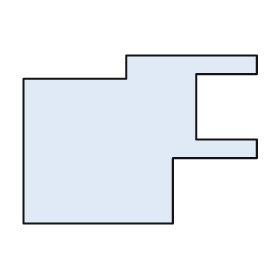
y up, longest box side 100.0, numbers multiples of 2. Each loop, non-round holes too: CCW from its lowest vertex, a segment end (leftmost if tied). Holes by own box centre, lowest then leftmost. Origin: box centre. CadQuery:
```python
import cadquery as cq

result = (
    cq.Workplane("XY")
    .moveTo(-50.0, -36.0)
    .lineTo(14.0, -36.0)
    .lineTo(14.0, -8.0)
    .lineTo(50.0, -8.0)
    .lineTo(50.0, 0.0)
    .lineTo(24.0, 0.0)
    .lineTo(24.0, 28.0)
    .lineTo(50.0, 28.0)
    .lineTo(50.0, 36.0)
    .lineTo(-6.0, 36.0)
    .lineTo(-6.0, 26.0)
    .lineTo(-50.0, 26.0)
    .close()
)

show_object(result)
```